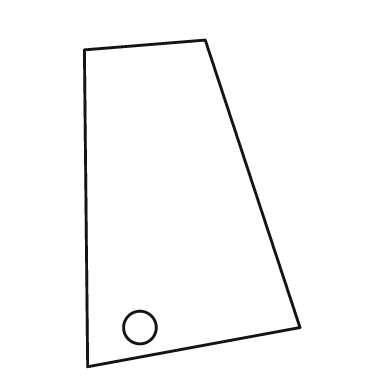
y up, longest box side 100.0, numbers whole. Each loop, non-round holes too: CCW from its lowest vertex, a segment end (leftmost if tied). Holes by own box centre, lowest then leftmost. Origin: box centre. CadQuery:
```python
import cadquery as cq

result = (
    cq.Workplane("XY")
    .moveTo(-32.0, -50.0)
    .lineTo(33.0, -38.0)
    .lineTo(4.0, 50.0)
    .lineTo(-33.0, 47.0)
    .close()
    .moveTo(-16.0, -38.0)
    .circle(5.0)
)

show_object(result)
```